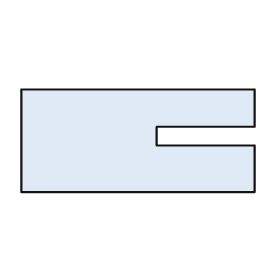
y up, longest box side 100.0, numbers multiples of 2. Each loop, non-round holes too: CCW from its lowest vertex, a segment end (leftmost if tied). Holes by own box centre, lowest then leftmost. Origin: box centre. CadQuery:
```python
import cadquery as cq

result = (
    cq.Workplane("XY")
    .moveTo(-50.0, -22.0)
    .lineTo(50.0, -22.0)
    .lineTo(50.0, -2.0)
    .lineTo(8.0, -2.0)
    .lineTo(8.0, 6.0)
    .lineTo(50.0, 6.0)
    .lineTo(50.0, 22.0)
    .lineTo(-50.0, 22.0)
    .close()
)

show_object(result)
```